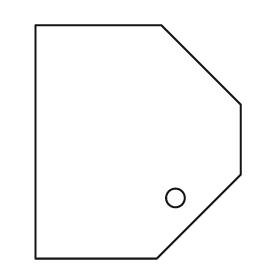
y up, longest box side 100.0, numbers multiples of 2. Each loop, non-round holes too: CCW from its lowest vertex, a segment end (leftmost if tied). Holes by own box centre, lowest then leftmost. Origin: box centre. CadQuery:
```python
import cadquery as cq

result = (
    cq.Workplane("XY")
    .moveTo(-44.0, -50.0)
    .lineTo(8.0, -50.0)
    .lineTo(44.0, -14.0)
    .lineTo(44.0, 16.0)
    .lineTo(10.0, 50.0)
    .lineTo(-44.0, 50.0)
    .close()
    .moveTo(16.0, -24.0)
    .circle(4.0)
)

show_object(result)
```